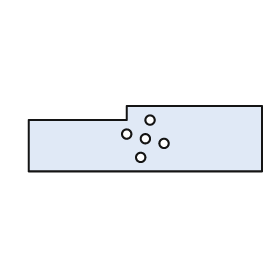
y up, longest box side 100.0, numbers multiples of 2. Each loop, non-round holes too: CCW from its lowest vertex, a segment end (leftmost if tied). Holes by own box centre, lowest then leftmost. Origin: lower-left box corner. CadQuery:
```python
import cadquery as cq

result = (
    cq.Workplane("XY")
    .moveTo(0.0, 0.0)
    .lineTo(100.0, 0.0)
    .lineTo(100.0, 28.0)
    .lineTo(42.0, 28.0)
    .lineTo(42.0, 22.0)
    .lineTo(0.0, 22.0)
    .close()
    .moveTo(48.0, 6.0)
    .circle(2.0)
    .moveTo(58.0, 12.0)
    .circle(2.0)
    .moveTo(50.0, 14.0)
    .circle(2.0)
    .moveTo(42.0, 16.0)
    .circle(2.0)
    .moveTo(52.0, 22.0)
    .circle(2.0)
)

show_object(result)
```